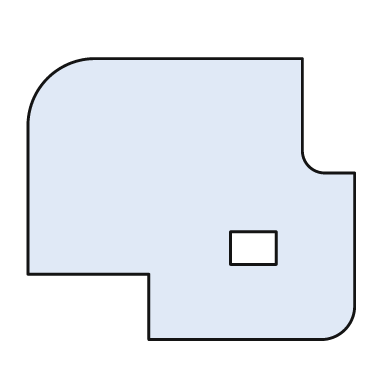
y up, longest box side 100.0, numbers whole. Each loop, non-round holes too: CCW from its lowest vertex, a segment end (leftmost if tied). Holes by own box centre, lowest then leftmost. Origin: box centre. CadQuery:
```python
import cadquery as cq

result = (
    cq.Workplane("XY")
    .moveTo(-13.0, -43.0)
    .lineTo(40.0, -43.0)
    .threePointArc((47.0, -40.0), (50.0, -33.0))
    .lineTo(50.0, 8.0)
    .lineTo(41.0, 8.0)
    .threePointArc((36.0, 10.0), (34.0, 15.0))
    .lineTo(34.0, 43.0)
    .lineTo(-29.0, 43.0)
    .threePointArc((-44.0, 37.0), (-50.0, 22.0))
    .lineTo(-50.0, -23.0)
    .lineTo(-13.0, -23.0)
    .close()
    .moveTo(12.0, -20.0)
    .lineTo(26.0, -20.0)
    .lineTo(26.0, -10.0)
    .lineTo(12.0, -10.0)
    .close()
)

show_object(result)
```